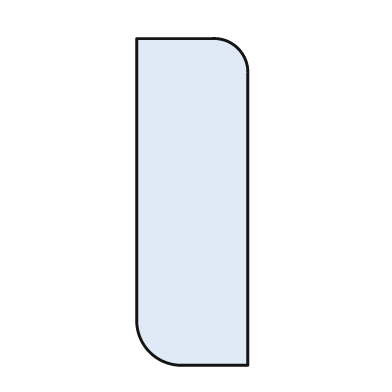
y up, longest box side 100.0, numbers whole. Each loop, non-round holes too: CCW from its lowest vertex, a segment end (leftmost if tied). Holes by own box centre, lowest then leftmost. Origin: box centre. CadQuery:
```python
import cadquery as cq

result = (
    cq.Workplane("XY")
    .moveTo(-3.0, -50.0)
    .lineTo(17.0, -50.0)
    .lineTo(17.0, 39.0)
    .threePointArc((14.0, 47.0), (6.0, 50.0))
    .lineTo(-17.0, 50.0)
    .lineTo(-17.0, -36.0)
    .threePointArc((-13.0, -46.0), (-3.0, -50.0))
    .close()
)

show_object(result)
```